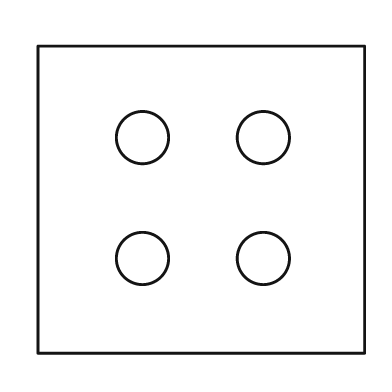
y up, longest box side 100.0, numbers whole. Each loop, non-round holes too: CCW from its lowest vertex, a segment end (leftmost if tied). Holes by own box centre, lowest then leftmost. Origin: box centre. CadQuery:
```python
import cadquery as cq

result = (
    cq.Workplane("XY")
    .moveTo(-50.0, -47.0)
    .lineTo(50.0, -47.0)
    .lineTo(50.0, 47.0)
    .lineTo(-50.0, 47.0)
    .close()
    .moveTo(-18.0, -18.0)
    .circle(8.0)
    .moveTo(19.0, -18.0)
    .circle(8.0)
    .moveTo(-18.0, 19.0)
    .circle(8.0)
    .moveTo(19.0, 19.0)
    .circle(8.0)
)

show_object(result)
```